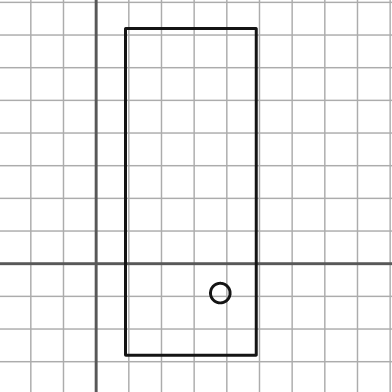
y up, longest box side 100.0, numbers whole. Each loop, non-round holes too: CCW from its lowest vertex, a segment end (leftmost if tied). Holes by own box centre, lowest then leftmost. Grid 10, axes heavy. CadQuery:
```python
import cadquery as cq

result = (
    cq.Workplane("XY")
    .moveTo(9.0, -28.0)
    .lineTo(49.0, -28.0)
    .lineTo(49.0, 72.0)
    .lineTo(9.0, 72.0)
    .close()
    .moveTo(38.0, -9.0)
    .circle(3.0)
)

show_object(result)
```